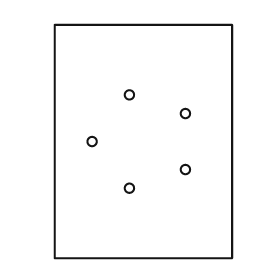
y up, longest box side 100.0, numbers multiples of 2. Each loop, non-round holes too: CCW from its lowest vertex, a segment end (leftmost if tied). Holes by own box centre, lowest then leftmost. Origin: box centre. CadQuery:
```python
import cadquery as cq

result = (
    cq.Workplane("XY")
    .moveTo(-38.0, -50.0)
    .lineTo(38.0, -50.0)
    .lineTo(38.0, 50.0)
    .lineTo(-38.0, 50.0)
    .close()
    .moveTo(-6.0, -20.0)
    .circle(2.0)
    .moveTo(18.0, -12.0)
    .circle(2.0)
    .moveTo(-22.0, 0.0)
    .circle(2.0)
    .moveTo(18.0, 12.0)
    .circle(2.0)
    .moveTo(-6.0, 20.0)
    .circle(2.0)
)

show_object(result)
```